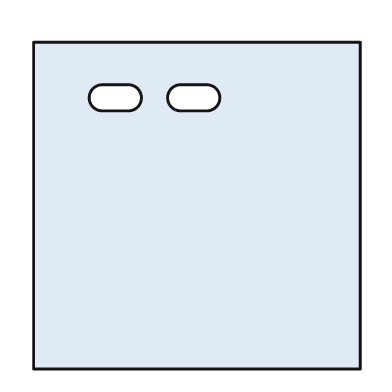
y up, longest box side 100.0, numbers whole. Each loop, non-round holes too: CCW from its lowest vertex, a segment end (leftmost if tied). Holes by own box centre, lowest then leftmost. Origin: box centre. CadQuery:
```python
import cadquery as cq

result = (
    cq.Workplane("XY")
    .moveTo(-50.0, -50.0)
    .lineTo(50.0, -50.0)
    .lineTo(50.0, 50.0)
    .lineTo(-50.0, 50.0)
    .close()
    .moveTo(-29.0, 29.0)
    .lineTo(-21.0, 29.0)
    .threePointArc((-17.0, 33.0), (-21.0, 37.0))
    .lineTo(-29.0, 37.0)
    .threePointArc((-33.0, 33.0), (-29.0, 29.0))
    .close()
    .moveTo(-5.0, 29.0)
    .lineTo(3.0, 29.0)
    .threePointArc((7.0, 33.0), (3.0, 37.0))
    .lineTo(-5.0, 37.0)
    .threePointArc((-9.0, 33.0), (-5.0, 29.0))
    .close()
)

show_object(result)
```